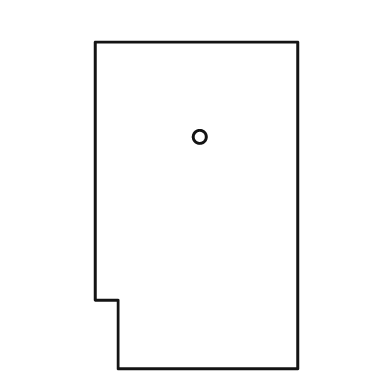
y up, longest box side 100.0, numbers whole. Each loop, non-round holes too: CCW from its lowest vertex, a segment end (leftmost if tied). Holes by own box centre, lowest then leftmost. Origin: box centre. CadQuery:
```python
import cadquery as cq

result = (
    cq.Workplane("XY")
    .moveTo(-24.0, -50.0)
    .lineTo(31.0, -50.0)
    .lineTo(31.0, 50.0)
    .lineTo(-31.0, 50.0)
    .lineTo(-31.0, -29.0)
    .lineTo(-24.0, -29.0)
    .close()
    .moveTo(1.0, 21.0)
    .circle(2.0)
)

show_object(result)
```